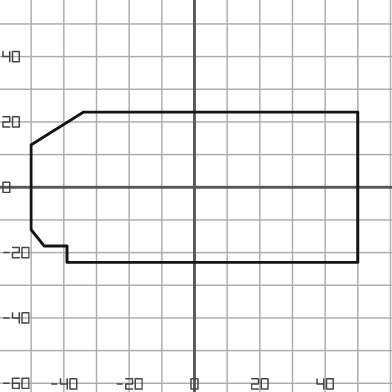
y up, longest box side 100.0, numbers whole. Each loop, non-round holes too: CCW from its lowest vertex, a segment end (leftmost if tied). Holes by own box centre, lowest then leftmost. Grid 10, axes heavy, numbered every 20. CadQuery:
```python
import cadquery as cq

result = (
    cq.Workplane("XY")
    .moveTo(-39.0, -23.0)
    .lineTo(50.0, -23.0)
    .lineTo(50.0, 23.0)
    .lineTo(-34.0, 23.0)
    .lineTo(-50.0, 13.0)
    .lineTo(-50.0, -13.0)
    .lineTo(-46.0, -18.0)
    .lineTo(-39.0, -18.0)
    .close()
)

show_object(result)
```